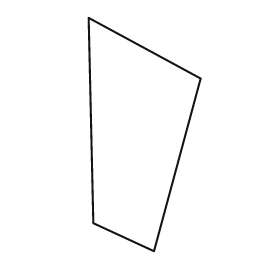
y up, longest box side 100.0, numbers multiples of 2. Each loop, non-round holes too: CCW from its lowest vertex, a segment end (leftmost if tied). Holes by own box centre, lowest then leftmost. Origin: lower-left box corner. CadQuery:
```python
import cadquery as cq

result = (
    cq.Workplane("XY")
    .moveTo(28.0, 0.0)
    .lineTo(48.0, 74.0)
    .lineTo(0.0, 100.0)
    .lineTo(2.0, 12.0)
    .close()
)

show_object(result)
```